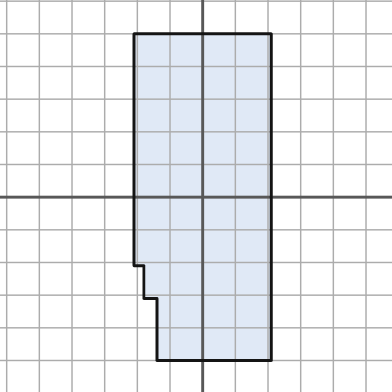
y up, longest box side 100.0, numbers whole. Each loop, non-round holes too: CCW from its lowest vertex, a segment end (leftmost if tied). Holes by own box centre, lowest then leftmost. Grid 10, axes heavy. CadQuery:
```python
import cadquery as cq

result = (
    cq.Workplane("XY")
    .moveTo(-14.0, -50.0)
    .lineTo(21.0, -50.0)
    .lineTo(21.0, 50.0)
    .lineTo(-21.0, 50.0)
    .lineTo(-21.0, -21.0)
    .lineTo(-18.0, -21.0)
    .lineTo(-18.0, -31.0)
    .lineTo(-14.0, -31.0)
    .close()
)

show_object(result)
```